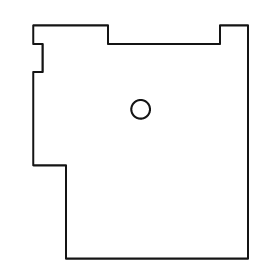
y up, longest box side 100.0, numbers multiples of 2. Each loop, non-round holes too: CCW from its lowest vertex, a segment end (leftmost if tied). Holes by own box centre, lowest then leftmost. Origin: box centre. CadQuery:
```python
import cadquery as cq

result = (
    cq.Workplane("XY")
    .moveTo(-32.0, -50.0)
    .lineTo(46.0, -50.0)
    .lineTo(46.0, 50.0)
    .lineTo(34.0, 50.0)
    .lineTo(34.0, 42.0)
    .lineTo(-14.0, 42.0)
    .lineTo(-14.0, 50.0)
    .lineTo(-46.0, 50.0)
    .lineTo(-46.0, 42.0)
    .lineTo(-42.0, 42.0)
    .lineTo(-42.0, 30.0)
    .lineTo(-46.0, 30.0)
    .lineTo(-46.0, -10.0)
    .lineTo(-32.0, -10.0)
    .close()
    .moveTo(0.0, 14.0)
    .circle(4.0)
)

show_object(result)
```